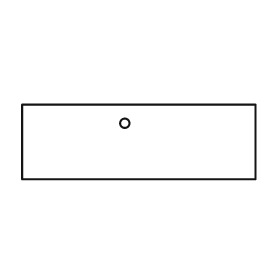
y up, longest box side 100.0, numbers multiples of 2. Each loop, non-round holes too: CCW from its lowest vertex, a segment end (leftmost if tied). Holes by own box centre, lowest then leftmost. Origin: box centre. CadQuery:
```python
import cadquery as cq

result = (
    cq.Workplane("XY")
    .moveTo(-50.0, -16.0)
    .lineTo(50.0, -16.0)
    .lineTo(50.0, 16.0)
    .lineTo(-50.0, 16.0)
    .close()
    .moveTo(-6.0, 8.0)
    .circle(2.0)
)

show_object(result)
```